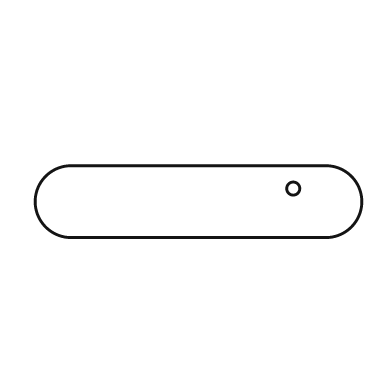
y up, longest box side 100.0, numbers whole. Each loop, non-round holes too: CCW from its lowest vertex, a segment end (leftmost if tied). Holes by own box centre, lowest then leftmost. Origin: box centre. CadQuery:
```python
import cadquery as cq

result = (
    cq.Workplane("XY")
    .moveTo(-39.0, -11.0)
    .lineTo(39.0, -11.0)
    .threePointArc((50.0, 0.0), (39.0, 11.0))
    .lineTo(-39.0, 11.0)
    .threePointArc((-50.0, 0.0), (-39.0, -11.0))
    .close()
    .moveTo(29.0, 4.0)
    .circle(2.0)
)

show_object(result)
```